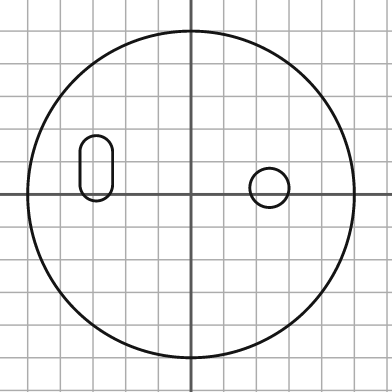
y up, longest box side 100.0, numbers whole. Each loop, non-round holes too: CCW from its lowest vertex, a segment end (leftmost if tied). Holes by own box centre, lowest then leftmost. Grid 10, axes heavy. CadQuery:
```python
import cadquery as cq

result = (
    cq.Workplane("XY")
    .moveTo(0.0, 0.0)
    .circle(50.0)
    .moveTo(24.0, 2.0)
    .circle(6.0)
    .moveTo(-34.0, 3.0)
    .threePointArc((-29.0, -2.0), (-24.0, 3.0))
    .lineTo(-24.0, 13.0)
    .threePointArc((-29.0, 18.0), (-34.0, 13.0))
    .close()
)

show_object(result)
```